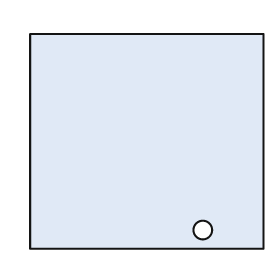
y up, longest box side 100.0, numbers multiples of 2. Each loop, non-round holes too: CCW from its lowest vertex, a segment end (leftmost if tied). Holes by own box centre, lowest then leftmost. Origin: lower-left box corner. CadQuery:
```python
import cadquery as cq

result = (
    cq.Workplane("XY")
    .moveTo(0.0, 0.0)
    .lineTo(100.0, 0.0)
    .lineTo(100.0, 92.0)
    .lineTo(0.0, 92.0)
    .close()
    .moveTo(74.0, 8.0)
    .circle(4.0)
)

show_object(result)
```